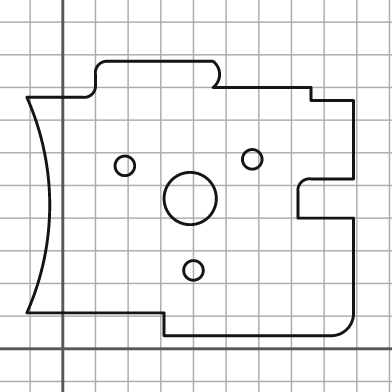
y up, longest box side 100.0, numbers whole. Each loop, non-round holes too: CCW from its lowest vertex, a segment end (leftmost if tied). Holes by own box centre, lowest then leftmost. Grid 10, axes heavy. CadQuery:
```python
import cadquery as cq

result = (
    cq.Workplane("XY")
    .moveTo(31.0, 4.0)
    .lineTo(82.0, 4.0)
    .threePointArc((87.0, 6.0), (89.0, 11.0))
    .lineTo(89.0, 40.0)
    .lineTo(72.0, 40.0)
    .lineTo(72.0, 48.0)
    .threePointArc((73.0, 51.0), (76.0, 52.0))
    .lineTo(89.0, 52.0)
    .lineTo(89.0, 76.0)
    .lineTo(76.0, 76.0)
    .lineTo(76.0, 80.0)
    .lineTo(46.0, 80.0)
    .threePointArc((48.0, 84.0), (46.0, 88.0))
    .lineTo(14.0, 88.0)
    .threePointArc((11.0, 87.0), (10.0, 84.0))
    .lineTo(10.0, 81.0)
    .threePointArc((9.0, 78.0), (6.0, 77.0))
    .lineTo(-11.0, 77.0)
    .threePointArc((-4.0, 44.0), (-11.0, 11.0))
    .lineTo(31.0, 11.0)
    .close()
    .moveTo(40.0, 24.0)
    .circle(3.0)
    .moveTo(39.0, 46.0)
    .circle(8.0)
    .moveTo(19.0, 56.0)
    .circle(3.0)
    .moveTo(58.0, 58.0)
    .circle(3.0)
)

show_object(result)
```